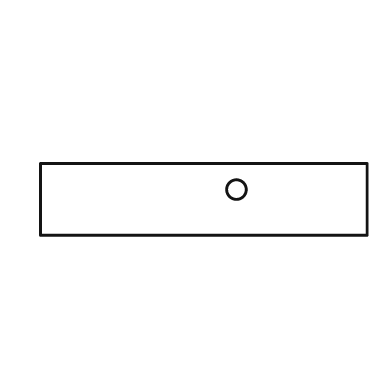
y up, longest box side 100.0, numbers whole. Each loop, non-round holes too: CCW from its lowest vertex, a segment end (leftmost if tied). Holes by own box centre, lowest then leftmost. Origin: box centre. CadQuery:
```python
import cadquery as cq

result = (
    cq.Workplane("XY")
    .moveTo(-50.0, -11.0)
    .lineTo(50.0, -11.0)
    .lineTo(50.0, 11.0)
    .lineTo(-50.0, 11.0)
    .close()
    .moveTo(10.0, 3.0)
    .circle(3.0)
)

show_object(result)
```